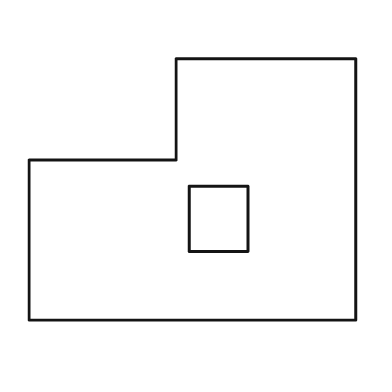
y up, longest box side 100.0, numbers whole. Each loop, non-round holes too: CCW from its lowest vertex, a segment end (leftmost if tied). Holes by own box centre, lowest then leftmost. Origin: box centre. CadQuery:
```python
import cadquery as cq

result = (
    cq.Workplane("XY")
    .moveTo(-50.0, -40.0)
    .lineTo(50.0, -40.0)
    .lineTo(50.0, 40.0)
    .lineTo(-5.0, 40.0)
    .lineTo(-5.0, 9.0)
    .lineTo(-50.0, 9.0)
    .close()
    .moveTo(-1.0, -19.0)
    .lineTo(17.0, -19.0)
    .lineTo(17.0, 1.0)
    .lineTo(-1.0, 1.0)
    .close()
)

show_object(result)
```